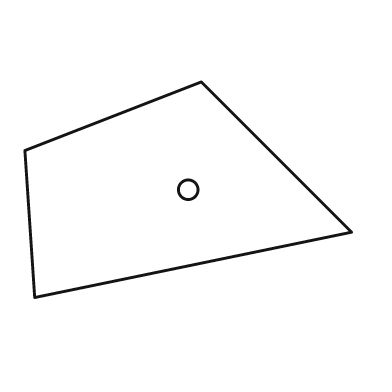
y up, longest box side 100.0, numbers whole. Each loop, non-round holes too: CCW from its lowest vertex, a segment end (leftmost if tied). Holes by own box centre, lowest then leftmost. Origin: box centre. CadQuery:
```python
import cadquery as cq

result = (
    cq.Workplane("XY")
    .moveTo(-47.0, -33.0)
    .lineTo(50.0, -13.0)
    .lineTo(4.0, 33.0)
    .lineTo(-50.0, 12.0)
    .close()
    .moveTo(0.0, 0.0)
    .circle(3.0)
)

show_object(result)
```